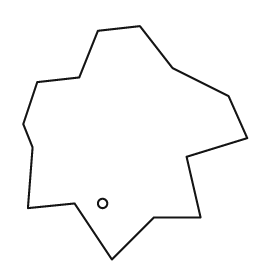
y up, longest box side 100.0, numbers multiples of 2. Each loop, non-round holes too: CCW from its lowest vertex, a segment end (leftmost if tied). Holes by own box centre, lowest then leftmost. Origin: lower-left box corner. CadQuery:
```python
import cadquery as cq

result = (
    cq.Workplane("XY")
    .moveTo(38.0, 0.0)
    .lineTo(56.0, 18.0)
    .lineTo(76.0, 18.0)
    .lineTo(70.0, 44.0)
    .lineTo(96.0, 52.0)
    .lineTo(88.0, 70.0)
    .lineTo(64.0, 82.0)
    .lineTo(50.0, 100.0)
    .lineTo(32.0, 98.0)
    .lineTo(24.0, 78.0)
    .lineTo(6.0, 76.0)
    .lineTo(0.0, 58.0)
    .lineTo(4.0, 48.0)
    .lineTo(2.0, 22.0)
    .lineTo(22.0, 24.0)
    .close()
    .moveTo(34.0, 24.0)
    .circle(2.0)
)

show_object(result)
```